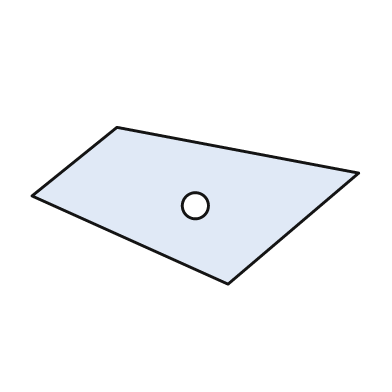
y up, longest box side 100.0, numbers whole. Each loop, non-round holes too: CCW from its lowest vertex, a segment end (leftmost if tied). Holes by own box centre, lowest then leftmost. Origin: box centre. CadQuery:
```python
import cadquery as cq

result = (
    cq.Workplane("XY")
    .moveTo(10.0, -24.0)
    .lineTo(50.0, 10.0)
    .lineTo(-24.0, 24.0)
    .lineTo(-50.0, 3.0)
    .close()
    .moveTo(0.0, 0.0)
    .circle(4.0)
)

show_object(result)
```